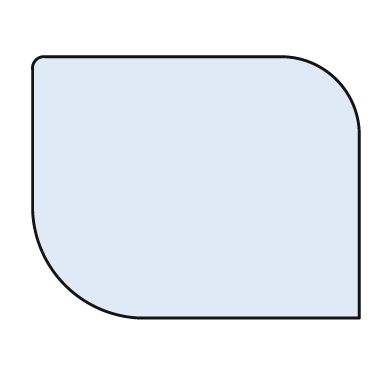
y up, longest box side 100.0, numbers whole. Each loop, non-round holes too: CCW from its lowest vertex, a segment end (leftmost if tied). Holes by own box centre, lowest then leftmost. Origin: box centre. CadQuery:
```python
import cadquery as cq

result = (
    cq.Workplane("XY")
    .moveTo(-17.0, -40.0)
    .lineTo(50.0, -40.0)
    .lineTo(50.0, 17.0)
    .threePointArc((43.0, 33.0), (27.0, 40.0))
    .lineTo(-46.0, 40.0)
    .threePointArc((-49.0, 39.0), (-50.0, 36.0))
    .lineTo(-50.0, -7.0)
    .threePointArc((-40.0, -30.0), (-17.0, -40.0))
    .close()
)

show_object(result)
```